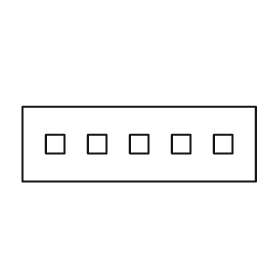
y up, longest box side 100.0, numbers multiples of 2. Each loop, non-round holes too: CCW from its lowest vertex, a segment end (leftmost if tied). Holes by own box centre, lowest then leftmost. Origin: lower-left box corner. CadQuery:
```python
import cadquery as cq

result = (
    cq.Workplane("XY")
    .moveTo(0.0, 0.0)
    .lineTo(100.0, 0.0)
    .lineTo(100.0, 32.0)
    .lineTo(0.0, 32.0)
    .close()
    .moveTo(10.0, 12.0)
    .lineTo(18.0, 12.0)
    .lineTo(18.0, 20.0)
    .lineTo(10.0, 20.0)
    .close()
    .moveTo(28.0, 12.0)
    .lineTo(36.0, 12.0)
    .lineTo(36.0, 20.0)
    .lineTo(28.0, 20.0)
    .close()
    .moveTo(46.0, 12.0)
    .lineTo(54.0, 12.0)
    .lineTo(54.0, 20.0)
    .lineTo(46.0, 20.0)
    .close()
    .moveTo(64.0, 12.0)
    .lineTo(72.0, 12.0)
    .lineTo(72.0, 20.0)
    .lineTo(64.0, 20.0)
    .close()
    .moveTo(82.0, 12.0)
    .lineTo(90.0, 12.0)
    .lineTo(90.0, 20.0)
    .lineTo(82.0, 20.0)
    .close()
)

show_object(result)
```